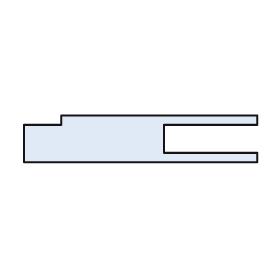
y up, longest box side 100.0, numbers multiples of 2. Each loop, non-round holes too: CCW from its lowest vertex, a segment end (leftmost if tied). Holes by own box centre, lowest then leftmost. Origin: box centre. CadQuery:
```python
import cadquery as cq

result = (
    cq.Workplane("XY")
    .moveTo(-50.0, -10.0)
    .lineTo(50.0, -10.0)
    .lineTo(50.0, -6.0)
    .lineTo(10.0, -6.0)
    .lineTo(10.0, 6.0)
    .lineTo(50.0, 6.0)
    .lineTo(50.0, 10.0)
    .lineTo(-34.0, 10.0)
    .lineTo(-34.0, 6.0)
    .lineTo(-50.0, 6.0)
    .close()
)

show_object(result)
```